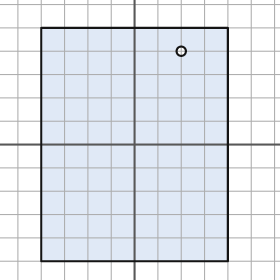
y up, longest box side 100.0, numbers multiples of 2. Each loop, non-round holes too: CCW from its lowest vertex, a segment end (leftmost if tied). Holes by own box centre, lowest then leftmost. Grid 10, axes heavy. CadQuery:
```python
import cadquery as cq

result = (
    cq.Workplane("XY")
    .moveTo(-40.0, -50.0)
    .lineTo(40.0, -50.0)
    .lineTo(40.0, 50.0)
    .lineTo(-40.0, 50.0)
    .close()
    .moveTo(20.0, 40.0)
    .circle(2.0)
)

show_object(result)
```